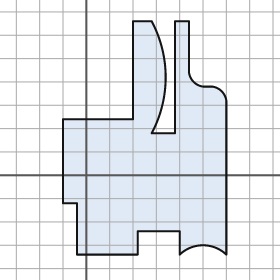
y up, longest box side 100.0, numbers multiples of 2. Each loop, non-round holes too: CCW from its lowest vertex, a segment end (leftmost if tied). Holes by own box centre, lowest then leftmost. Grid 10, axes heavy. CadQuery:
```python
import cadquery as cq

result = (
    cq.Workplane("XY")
    .moveTo(-4.0, -34.0)
    .lineTo(22.0, -34.0)
    .lineTo(22.0, -24.0)
    .lineTo(40.0, -24.0)
    .lineTo(40.0, -34.0)
    .threePointArc((50.0, -30.0), (60.0, -34.0))
    .lineTo(60.0, 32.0)
    .threePointArc((58.0, 36.0), (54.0, 38.0))
    .lineTo(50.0, 38.0)
    .threePointArc((46.0, 40.0), (44.0, 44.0))
    .lineTo(44.0, 66.0)
    .lineTo(38.0, 66.0)
    .lineTo(38.0, 18.0)
    .lineTo(28.0, 18.0)
    .threePointArc((34.0, 42.0), (28.0, 66.0))
    .lineTo(20.0, 66.0)
    .lineTo(20.0, 24.0)
    .lineTo(-10.0, 24.0)
    .lineTo(-10.0, -12.0)
    .lineTo(-4.0, -12.0)
    .close()
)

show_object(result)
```